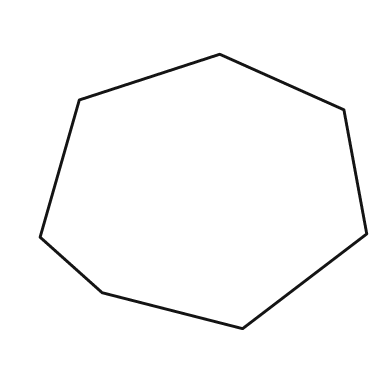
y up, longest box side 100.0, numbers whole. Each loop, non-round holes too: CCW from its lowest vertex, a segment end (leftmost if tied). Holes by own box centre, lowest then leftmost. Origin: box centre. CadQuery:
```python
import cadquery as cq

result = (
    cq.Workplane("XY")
    .moveTo(12.0, -42.0)
    .lineTo(50.0, -13.0)
    .lineTo(43.0, 25.0)
    .lineTo(5.0, 42.0)
    .lineTo(-38.0, 28.0)
    .lineTo(-50.0, -14.0)
    .lineTo(-31.0, -31.0)
    .close()
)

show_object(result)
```